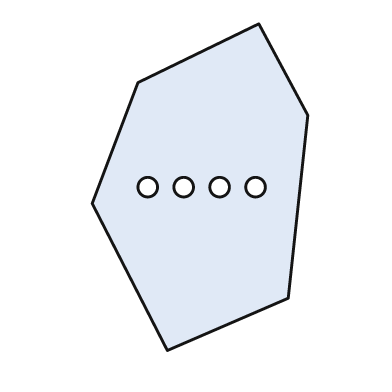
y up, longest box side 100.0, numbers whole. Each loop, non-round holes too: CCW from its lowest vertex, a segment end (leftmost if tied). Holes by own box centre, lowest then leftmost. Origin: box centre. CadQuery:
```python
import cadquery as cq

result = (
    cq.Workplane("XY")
    .moveTo(-10.0, -50.0)
    .lineTo(27.0, -34.0)
    .lineTo(33.0, 22.0)
    .lineTo(18.0, 50.0)
    .lineTo(-19.0, 32.0)
    .lineTo(-33.0, -5.0)
    .close()
    .moveTo(-16.0, 0.0)
    .circle(3.0)
    .moveTo(-5.0, 0.0)
    .circle(3.0)
    .moveTo(6.0, 0.0)
    .circle(3.0)
    .moveTo(17.0, 0.0)
    .circle(3.0)
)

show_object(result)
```